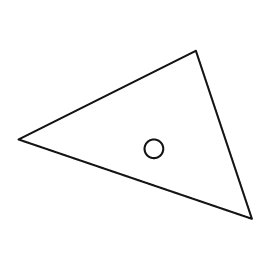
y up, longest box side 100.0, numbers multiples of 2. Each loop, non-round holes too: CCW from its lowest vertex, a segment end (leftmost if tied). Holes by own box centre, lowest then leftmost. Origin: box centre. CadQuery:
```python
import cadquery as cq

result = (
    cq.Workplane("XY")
    .moveTo(50.0, -36.0)
    .lineTo(26.0, 36.0)
    .lineTo(-50.0, -2.0)
    .close()
    .moveTo(8.0, -6.0)
    .circle(4.0)
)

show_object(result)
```